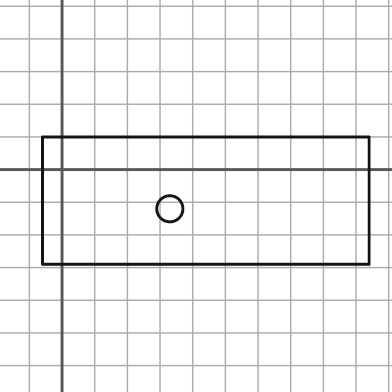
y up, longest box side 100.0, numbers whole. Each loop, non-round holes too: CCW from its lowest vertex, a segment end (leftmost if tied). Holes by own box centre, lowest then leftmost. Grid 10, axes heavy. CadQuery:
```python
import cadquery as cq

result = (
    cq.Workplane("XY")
    .moveTo(-6.0, -29.0)
    .lineTo(94.0, -29.0)
    .lineTo(94.0, 10.0)
    .lineTo(-6.0, 10.0)
    .close()
    .moveTo(33.0, -12.0)
    .circle(4.0)
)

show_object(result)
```